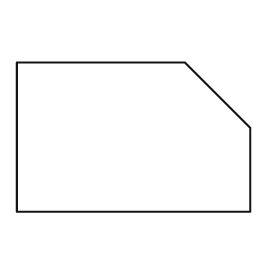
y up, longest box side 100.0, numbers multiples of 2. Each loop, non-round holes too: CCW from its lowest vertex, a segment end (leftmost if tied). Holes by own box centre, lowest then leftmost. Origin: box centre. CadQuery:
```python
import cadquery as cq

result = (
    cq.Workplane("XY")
    .moveTo(-50.0, -32.0)
    .lineTo(50.0, -32.0)
    .lineTo(50.0, 4.0)
    .lineTo(22.0, 32.0)
    .lineTo(-50.0, 32.0)
    .close()
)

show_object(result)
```